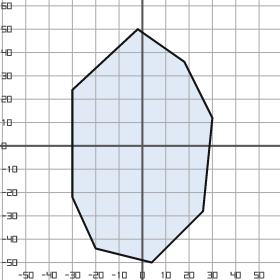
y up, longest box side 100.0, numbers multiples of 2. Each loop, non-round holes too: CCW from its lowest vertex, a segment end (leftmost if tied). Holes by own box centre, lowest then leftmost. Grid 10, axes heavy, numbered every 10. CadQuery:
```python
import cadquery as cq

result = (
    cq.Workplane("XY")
    .moveTo(4.0, -50.0)
    .lineTo(26.0, -28.0)
    .lineTo(30.0, 12.0)
    .lineTo(18.0, 36.0)
    .lineTo(-2.0, 50.0)
    .lineTo(-30.0, 24.0)
    .lineTo(-30.0, -22.0)
    .lineTo(-20.0, -44.0)
    .close()
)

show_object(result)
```